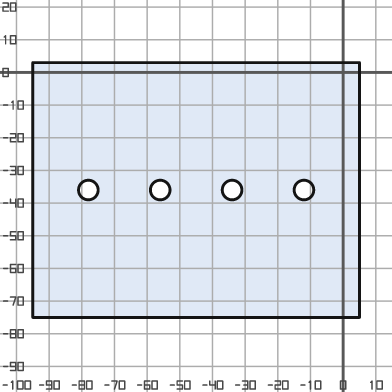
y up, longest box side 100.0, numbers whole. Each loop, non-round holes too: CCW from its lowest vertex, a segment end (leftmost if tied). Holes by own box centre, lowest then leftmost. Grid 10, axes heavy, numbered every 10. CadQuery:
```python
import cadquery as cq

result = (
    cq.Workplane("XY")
    .moveTo(-95.0, -75.0)
    .lineTo(5.0, -75.0)
    .lineTo(5.0, 3.0)
    .lineTo(-95.0, 3.0)
    .close()
    .moveTo(-78.0, -36.0)
    .circle(3.0)
    .moveTo(-56.0, -36.0)
    .circle(3.0)
    .moveTo(-34.0, -36.0)
    .circle(3.0)
    .moveTo(-12.0, -36.0)
    .circle(3.0)
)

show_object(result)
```